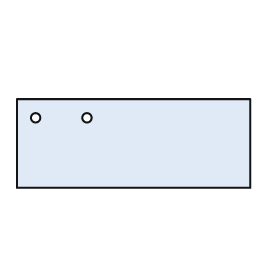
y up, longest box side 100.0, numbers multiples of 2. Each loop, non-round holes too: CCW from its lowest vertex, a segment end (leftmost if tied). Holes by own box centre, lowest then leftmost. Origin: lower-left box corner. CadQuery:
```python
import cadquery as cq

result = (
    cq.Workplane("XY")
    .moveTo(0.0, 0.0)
    .lineTo(100.0, 0.0)
    .lineTo(100.0, 38.0)
    .lineTo(0.0, 38.0)
    .close()
    .moveTo(8.0, 30.0)
    .circle(2.0)
    .moveTo(30.0, 30.0)
    .circle(2.0)
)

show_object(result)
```